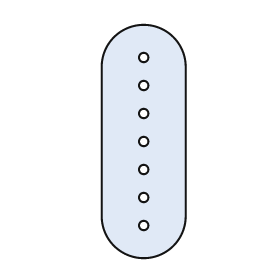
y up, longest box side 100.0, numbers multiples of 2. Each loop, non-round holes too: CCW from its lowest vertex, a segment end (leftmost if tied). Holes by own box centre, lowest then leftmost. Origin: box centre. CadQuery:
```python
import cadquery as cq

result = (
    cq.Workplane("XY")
    .moveTo(-18.0, -32.0)
    .threePointArc((0.0, -50.0), (18.0, -32.0))
    .lineTo(18.0, 32.0)
    .threePointArc((0.0, 50.0), (-18.0, 32.0))
    .close()
    .moveTo(0.0, -36.0)
    .circle(2.0)
    .moveTo(0.0, -24.0)
    .circle(2.0)
    .moveTo(0.0, -12.0)
    .circle(2.0)
    .moveTo(0.0, 0.0)
    .circle(2.0)
    .moveTo(0.0, 12.0)
    .circle(2.0)
    .moveTo(0.0, 24.0)
    .circle(2.0)
    .moveTo(0.0, 36.0)
    .circle(2.0)
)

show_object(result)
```